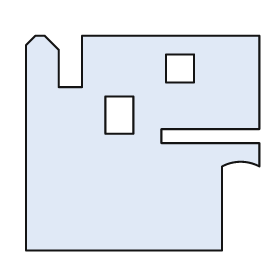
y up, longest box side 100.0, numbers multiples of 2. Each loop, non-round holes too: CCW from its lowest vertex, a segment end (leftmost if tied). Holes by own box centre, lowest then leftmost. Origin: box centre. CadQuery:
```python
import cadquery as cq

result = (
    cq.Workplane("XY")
    .moveTo(-50.0, -46.0)
    .lineTo(34.0, -46.0)
    .lineTo(34.0, -10.0)
    .threePointArc((42.0, -8.0), (50.0, -10.0))
    .lineTo(50.0, 0.0)
    .lineTo(8.0, 0.0)
    .lineTo(8.0, 6.0)
    .lineTo(50.0, 6.0)
    .lineTo(50.0, 46.0)
    .lineTo(-26.0, 46.0)
    .lineTo(-26.0, 24.0)
    .lineTo(-36.0, 24.0)
    .lineTo(-36.0, 40.0)
    .lineTo(-42.0, 46.0)
    .lineTo(-46.0, 46.0)
    .lineTo(-50.0, 42.0)
    .close()
    .moveTo(-16.0, 4.0)
    .lineTo(-4.0, 4.0)
    .lineTo(-4.0, 20.0)
    .lineTo(-16.0, 20.0)
    .close()
    .moveTo(10.0, 26.0)
    .lineTo(22.0, 26.0)
    .lineTo(22.0, 38.0)
    .lineTo(10.0, 38.0)
    .close()
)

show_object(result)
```